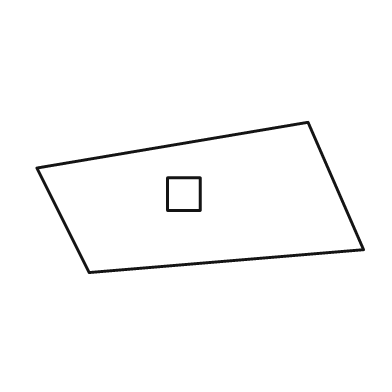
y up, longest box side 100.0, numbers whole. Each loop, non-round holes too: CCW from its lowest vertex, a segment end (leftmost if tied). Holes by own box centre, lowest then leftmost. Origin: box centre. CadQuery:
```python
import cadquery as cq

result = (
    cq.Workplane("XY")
    .moveTo(-34.0, -23.0)
    .lineTo(50.0, -16.0)
    .lineTo(33.0, 23.0)
    .lineTo(-50.0, 9.0)
    .close()
    .moveTo(-10.0, -4.0)
    .lineTo(0.0, -4.0)
    .lineTo(0.0, 6.0)
    .lineTo(-10.0, 6.0)
    .close()
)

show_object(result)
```